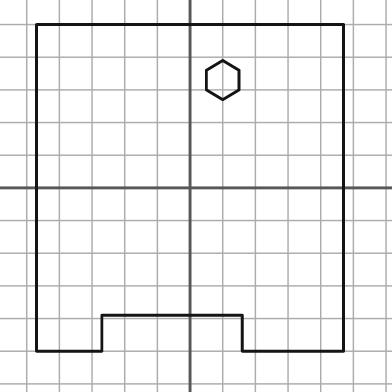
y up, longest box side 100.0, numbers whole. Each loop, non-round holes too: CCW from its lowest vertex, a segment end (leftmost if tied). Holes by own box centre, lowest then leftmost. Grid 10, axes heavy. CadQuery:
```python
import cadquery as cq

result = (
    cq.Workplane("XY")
    .moveTo(-47.0, -50.0)
    .lineTo(-27.0, -50.0)
    .lineTo(-27.0, -39.0)
    .lineTo(16.0, -39.0)
    .lineTo(16.0, -50.0)
    .lineTo(47.0, -50.0)
    .lineTo(47.0, 50.0)
    .lineTo(-47.0, 50.0)
    .close()
    .moveTo(10.0, 27.0)
    .lineTo(15.0, 30.0)
    .lineTo(15.0, 36.0)
    .lineTo(10.0, 39.0)
    .lineTo(5.0, 36.0)
    .lineTo(5.0, 30.0)
    .close()
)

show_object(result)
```